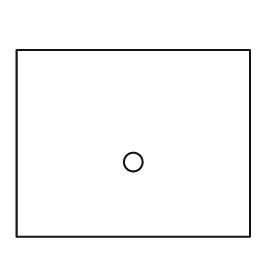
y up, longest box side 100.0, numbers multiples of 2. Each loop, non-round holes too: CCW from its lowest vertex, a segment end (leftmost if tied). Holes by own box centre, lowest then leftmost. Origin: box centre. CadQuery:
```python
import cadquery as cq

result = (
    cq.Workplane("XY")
    .moveTo(-50.0, -40.0)
    .lineTo(50.0, -40.0)
    .lineTo(50.0, 40.0)
    .lineTo(-50.0, 40.0)
    .close()
    .moveTo(0.0, -8.0)
    .circle(4.0)
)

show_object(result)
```